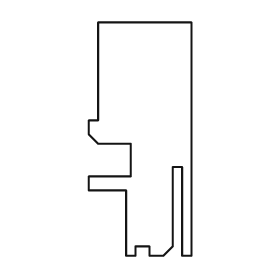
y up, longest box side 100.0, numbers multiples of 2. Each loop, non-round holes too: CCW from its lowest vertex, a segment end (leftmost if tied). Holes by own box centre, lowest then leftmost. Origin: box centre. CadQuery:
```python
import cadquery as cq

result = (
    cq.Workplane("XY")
    .moveTo(-6.0, -50.0)
    .lineTo(-2.0, -50.0)
    .lineTo(-2.0, -46.0)
    .lineTo(4.0, -46.0)
    .lineTo(4.0, -50.0)
    .lineTo(10.0, -50.0)
    .lineTo(14.0, -46.0)
    .lineTo(14.0, -12.0)
    .lineTo(18.0, -12.0)
    .lineTo(18.0, -50.0)
    .lineTo(22.0, -50.0)
    .lineTo(22.0, 50.0)
    .lineTo(-18.0, 50.0)
    .lineTo(-18.0, 8.0)
    .lineTo(-22.0, 8.0)
    .lineTo(-22.0, 2.0)
    .lineTo(-18.0, -2.0)
    .lineTo(-4.0, -2.0)
    .lineTo(-4.0, -16.0)
    .lineTo(-22.0, -16.0)
    .lineTo(-22.0, -22.0)
    .lineTo(-6.0, -22.0)
    .close()
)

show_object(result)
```